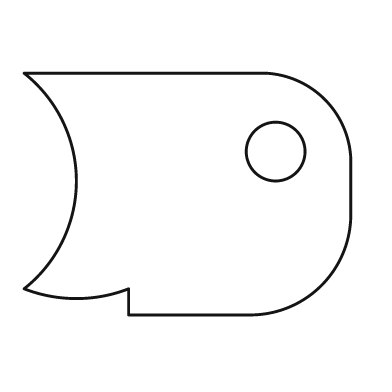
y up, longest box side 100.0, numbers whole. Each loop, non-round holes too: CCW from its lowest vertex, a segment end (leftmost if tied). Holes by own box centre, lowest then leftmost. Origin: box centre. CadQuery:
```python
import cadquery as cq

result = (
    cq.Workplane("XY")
    .moveTo(-18.0, -37.0)
    .lineTo(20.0, -37.0)
    .threePointArc((41.0, -28.0), (50.0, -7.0))
    .lineTo(50.0, 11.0)
    .threePointArc((42.0, 29.0), (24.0, 37.0))
    .lineTo(-50.0, 37.0)
    .threePointArc((-34.0, 4.0), (-50.0, -29.0))
    .threePointArc((-34.0, -32.0), (-18.0, -29.0))
    .close()
    .moveTo(27.0, 13.0)
    .circle(9.0)
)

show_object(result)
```